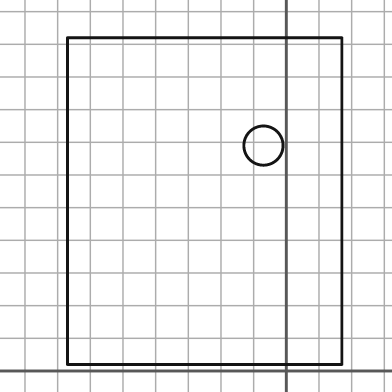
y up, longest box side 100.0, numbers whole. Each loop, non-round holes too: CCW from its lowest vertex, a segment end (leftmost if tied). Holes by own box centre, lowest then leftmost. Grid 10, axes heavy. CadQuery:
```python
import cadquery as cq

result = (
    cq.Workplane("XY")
    .moveTo(-67.0, 2.0)
    .lineTo(17.0, 2.0)
    .lineTo(17.0, 102.0)
    .lineTo(-67.0, 102.0)
    .close()
    .moveTo(-7.0, 69.0)
    .circle(6.0)
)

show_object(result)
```